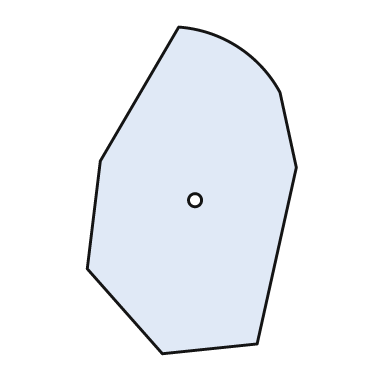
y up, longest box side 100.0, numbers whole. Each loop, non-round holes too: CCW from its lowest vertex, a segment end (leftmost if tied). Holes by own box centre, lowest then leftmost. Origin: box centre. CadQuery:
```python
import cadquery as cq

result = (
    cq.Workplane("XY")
    .moveTo(-9.0, -50.0)
    .lineTo(20.0, -47.0)
    .lineTo(32.0, 7.0)
    .lineTo(27.0, 30.0)
    .threePointArc((14.0, 44.0), (-4.0, 50.0))
    .lineTo(-28.0, 9.0)
    .lineTo(-32.0, -24.0)
    .close()
    .moveTo(1.0, -3.0)
    .circle(2.0)
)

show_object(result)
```